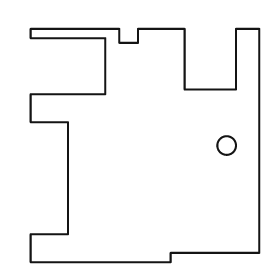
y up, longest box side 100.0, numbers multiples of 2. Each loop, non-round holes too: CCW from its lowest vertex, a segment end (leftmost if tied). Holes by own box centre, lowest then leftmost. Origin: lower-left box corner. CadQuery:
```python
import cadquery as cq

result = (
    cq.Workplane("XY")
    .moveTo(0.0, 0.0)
    .lineTo(60.0, 0.0)
    .lineTo(60.0, 4.0)
    .lineTo(98.0, 4.0)
    .lineTo(98.0, 100.0)
    .lineTo(88.0, 100.0)
    .lineTo(88.0, 74.0)
    .lineTo(66.0, 74.0)
    .lineTo(66.0, 100.0)
    .lineTo(46.0, 100.0)
    .lineTo(46.0, 94.0)
    .lineTo(38.0, 94.0)
    .lineTo(38.0, 100.0)
    .lineTo(0.0, 100.0)
    .lineTo(0.0, 96.0)
    .lineTo(32.0, 96.0)
    .lineTo(32.0, 72.0)
    .lineTo(0.0, 72.0)
    .lineTo(0.0, 60.0)
    .lineTo(16.0, 60.0)
    .lineTo(16.0, 12.0)
    .lineTo(0.0, 12.0)
    .close()
    .moveTo(84.0, 50.0)
    .circle(4.0)
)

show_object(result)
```